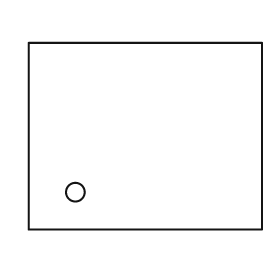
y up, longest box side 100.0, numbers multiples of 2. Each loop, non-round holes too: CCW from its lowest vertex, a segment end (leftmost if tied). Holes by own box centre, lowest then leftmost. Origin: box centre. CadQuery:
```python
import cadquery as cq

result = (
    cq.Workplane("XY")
    .moveTo(-50.0, -40.0)
    .lineTo(50.0, -40.0)
    .lineTo(50.0, 40.0)
    .lineTo(-50.0, 40.0)
    .close()
    .moveTo(-30.0, -24.0)
    .circle(4.0)
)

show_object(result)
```